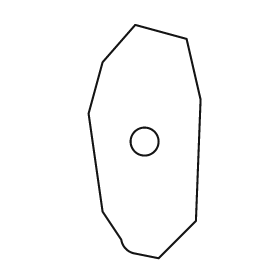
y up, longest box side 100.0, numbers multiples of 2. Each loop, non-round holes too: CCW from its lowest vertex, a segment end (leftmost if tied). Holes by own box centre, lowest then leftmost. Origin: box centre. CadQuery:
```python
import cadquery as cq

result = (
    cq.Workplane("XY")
    .moveTo(6.0, -50.0)
    .lineTo(22.0, -34.0)
    .lineTo(24.0, 18.0)
    .lineTo(18.0, 44.0)
    .lineTo(-4.0, 50.0)
    .lineTo(-18.0, 34.0)
    .lineTo(-24.0, 12.0)
    .lineTo(-18.0, -30.0)
    .lineTo(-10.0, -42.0)
    .threePointArc((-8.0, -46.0), (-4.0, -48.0))
    .close()
    .moveTo(0.0, 0.0)
    .circle(6.0)
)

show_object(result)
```